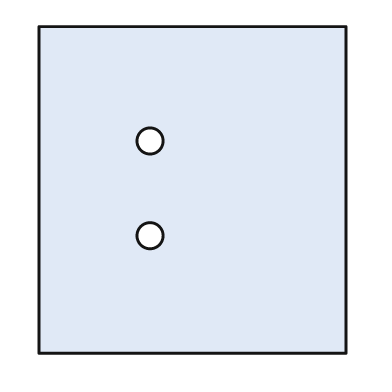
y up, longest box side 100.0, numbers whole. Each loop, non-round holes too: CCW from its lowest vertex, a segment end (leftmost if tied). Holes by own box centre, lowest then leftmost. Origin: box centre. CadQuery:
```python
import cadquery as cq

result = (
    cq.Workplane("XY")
    .moveTo(-47.0, -50.0)
    .lineTo(47.0, -50.0)
    .lineTo(47.0, 50.0)
    .lineTo(-47.0, 50.0)
    .close()
    .moveTo(-13.0, -14.0)
    .circle(4.0)
    .moveTo(-13.0, 15.0)
    .circle(4.0)
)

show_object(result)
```